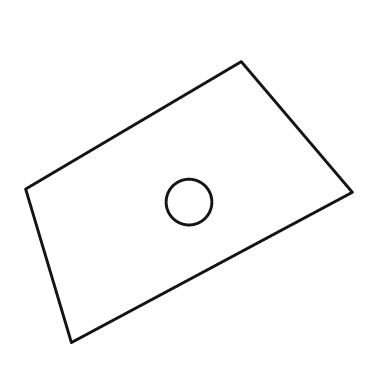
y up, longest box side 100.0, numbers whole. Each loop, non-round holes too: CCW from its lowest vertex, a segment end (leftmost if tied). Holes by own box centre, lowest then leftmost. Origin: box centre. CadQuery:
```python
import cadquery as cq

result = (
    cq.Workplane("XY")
    .moveTo(-36.0, -43.0)
    .lineTo(50.0, 3.0)
    .lineTo(16.0, 43.0)
    .lineTo(-50.0, 4.0)
    .close()
    .moveTo(0.0, 0.0)
    .circle(7.0)
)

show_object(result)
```